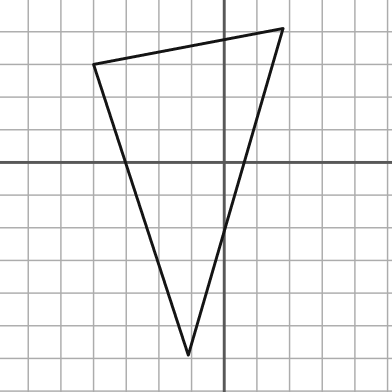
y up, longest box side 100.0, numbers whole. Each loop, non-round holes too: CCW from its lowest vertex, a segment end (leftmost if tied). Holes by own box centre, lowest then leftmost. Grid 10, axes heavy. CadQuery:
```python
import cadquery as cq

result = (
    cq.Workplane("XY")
    .moveTo(-11.0, -59.0)
    .lineTo(18.0, 41.0)
    .lineTo(-40.0, 30.0)
    .close()
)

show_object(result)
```